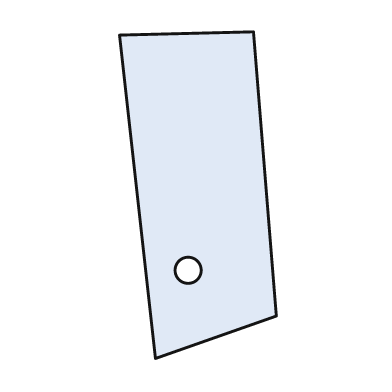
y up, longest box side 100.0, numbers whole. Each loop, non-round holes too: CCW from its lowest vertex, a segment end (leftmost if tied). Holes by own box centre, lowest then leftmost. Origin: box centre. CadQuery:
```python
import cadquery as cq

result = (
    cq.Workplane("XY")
    .moveTo(-13.0, -50.0)
    .lineTo(24.0, -37.0)
    .lineTo(17.0, 50.0)
    .lineTo(-24.0, 49.0)
    .close()
    .moveTo(-3.0, -23.0)
    .circle(4.0)
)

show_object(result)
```